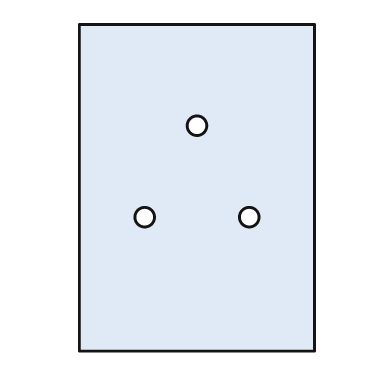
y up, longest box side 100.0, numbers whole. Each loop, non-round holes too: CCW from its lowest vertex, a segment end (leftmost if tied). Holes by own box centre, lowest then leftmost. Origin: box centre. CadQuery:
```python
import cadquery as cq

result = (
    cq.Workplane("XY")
    .moveTo(-36.0, -50.0)
    .lineTo(36.0, -50.0)
    .lineTo(36.0, 50.0)
    .lineTo(-36.0, 50.0)
    .close()
    .moveTo(-16.0, -9.0)
    .circle(3.0)
    .moveTo(16.0, -9.0)
    .circle(3.0)
    .moveTo(0.0, 19.0)
    .circle(3.0)
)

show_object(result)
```